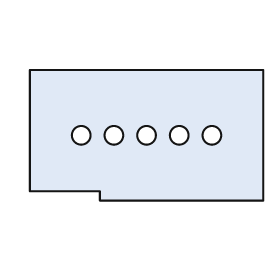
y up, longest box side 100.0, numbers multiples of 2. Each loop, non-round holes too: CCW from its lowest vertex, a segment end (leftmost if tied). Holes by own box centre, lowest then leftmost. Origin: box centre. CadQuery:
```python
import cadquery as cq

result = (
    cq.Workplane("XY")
    .moveTo(-20.0, -28.0)
    .lineTo(50.0, -28.0)
    .lineTo(50.0, 28.0)
    .lineTo(-50.0, 28.0)
    .lineTo(-50.0, -24.0)
    .lineTo(-20.0, -24.0)
    .close()
    .moveTo(-28.0, 0.0)
    .circle(4.0)
    .moveTo(-14.0, 0.0)
    .circle(4.0)
    .moveTo(0.0, 0.0)
    .circle(4.0)
    .moveTo(14.0, 0.0)
    .circle(4.0)
    .moveTo(28.0, 0.0)
    .circle(4.0)
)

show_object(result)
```